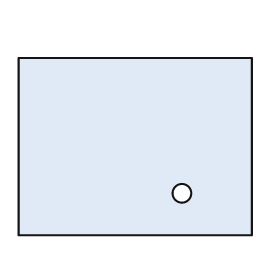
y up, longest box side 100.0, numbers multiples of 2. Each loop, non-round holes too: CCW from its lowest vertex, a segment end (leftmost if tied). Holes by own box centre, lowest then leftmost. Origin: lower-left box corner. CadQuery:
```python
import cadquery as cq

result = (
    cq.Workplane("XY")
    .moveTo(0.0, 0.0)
    .lineTo(100.0, 0.0)
    .lineTo(100.0, 76.0)
    .lineTo(0.0, 76.0)
    .close()
    .moveTo(70.0, 18.0)
    .circle(4.0)
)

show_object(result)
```